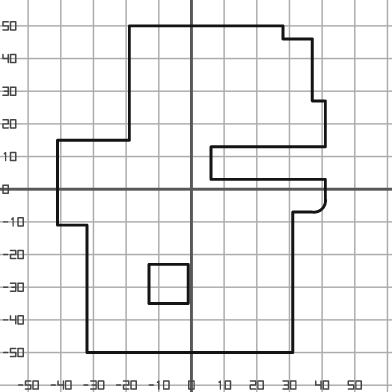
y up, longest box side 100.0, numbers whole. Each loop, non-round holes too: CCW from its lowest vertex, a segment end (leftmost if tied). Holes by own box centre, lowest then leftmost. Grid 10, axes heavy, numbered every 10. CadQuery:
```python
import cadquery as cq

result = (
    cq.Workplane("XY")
    .moveTo(-32.0, -50.0)
    .lineTo(31.0, -50.0)
    .lineTo(31.0, -7.0)
    .lineTo(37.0, -7.0)
    .threePointArc((40.0, -6.0), (41.0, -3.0))
    .lineTo(41.0, 3.0)
    .lineTo(6.0, 3.0)
    .lineTo(6.0, 13.0)
    .lineTo(41.0, 13.0)
    .lineTo(41.0, 27.0)
    .lineTo(37.0, 27.0)
    .lineTo(37.0, 46.0)
    .lineTo(28.0, 46.0)
    .lineTo(28.0, 50.0)
    .lineTo(-19.0, 50.0)
    .lineTo(-19.0, 15.0)
    .lineTo(-41.0, 15.0)
    .lineTo(-41.0, -11.0)
    .lineTo(-32.0, -11.0)
    .close()
    .moveTo(-13.0, -35.0)
    .lineTo(-1.0, -35.0)
    .lineTo(-1.0, -23.0)
    .lineTo(-13.0, -23.0)
    .close()
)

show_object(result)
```